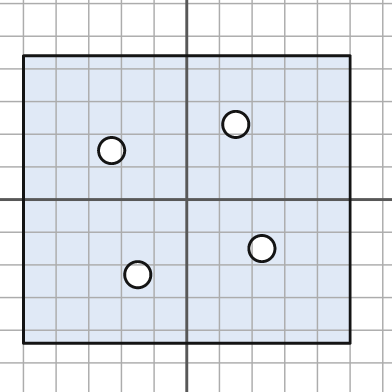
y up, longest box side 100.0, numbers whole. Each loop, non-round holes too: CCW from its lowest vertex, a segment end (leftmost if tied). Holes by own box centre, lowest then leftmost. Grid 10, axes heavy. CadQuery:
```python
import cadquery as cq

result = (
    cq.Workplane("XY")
    .moveTo(-50.0, -44.0)
    .lineTo(50.0, -44.0)
    .lineTo(50.0, 44.0)
    .lineTo(-50.0, 44.0)
    .close()
    .moveTo(-15.0, -23.0)
    .circle(4.0)
    .moveTo(23.0, -15.0)
    .circle(4.0)
    .moveTo(-23.0, 15.0)
    .circle(4.0)
    .moveTo(15.0, 23.0)
    .circle(4.0)
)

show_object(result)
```